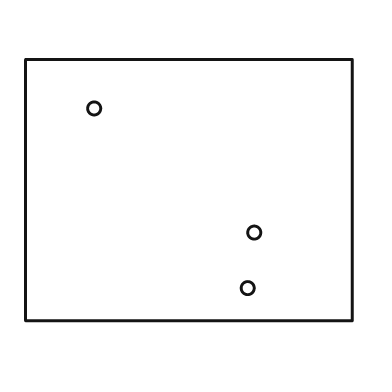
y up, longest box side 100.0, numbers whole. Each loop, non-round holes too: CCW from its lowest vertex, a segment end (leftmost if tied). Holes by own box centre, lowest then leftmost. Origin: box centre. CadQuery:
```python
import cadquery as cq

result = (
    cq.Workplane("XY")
    .moveTo(-50.0, -40.0)
    .lineTo(50.0, -40.0)
    .lineTo(50.0, 40.0)
    .lineTo(-50.0, 40.0)
    .close()
    .moveTo(18.0, -30.0)
    .circle(2.0)
    .moveTo(20.0, -13.0)
    .circle(2.0)
    .moveTo(-29.0, 25.0)
    .circle(2.0)
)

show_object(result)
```